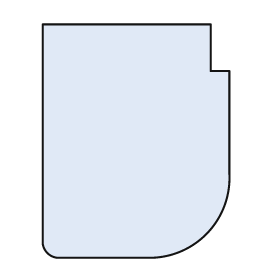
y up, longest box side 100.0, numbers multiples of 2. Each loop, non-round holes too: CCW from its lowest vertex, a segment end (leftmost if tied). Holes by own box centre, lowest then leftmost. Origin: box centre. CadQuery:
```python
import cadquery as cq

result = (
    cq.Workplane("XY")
    .moveTo(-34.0, -50.0)
    .lineTo(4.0, -50.0)
    .threePointArc((30.0, -40.0), (40.0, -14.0))
    .lineTo(40.0, 30.0)
    .lineTo(32.0, 30.0)
    .lineTo(32.0, 50.0)
    .lineTo(-40.0, 50.0)
    .lineTo(-40.0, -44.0)
    .threePointArc((-38.0, -48.0), (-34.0, -50.0))
    .close()
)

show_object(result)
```